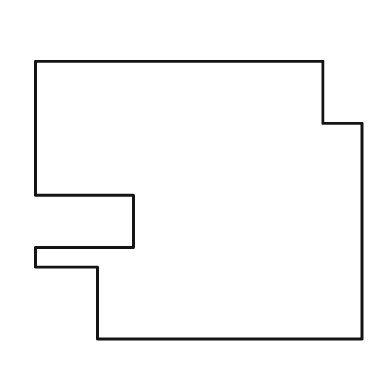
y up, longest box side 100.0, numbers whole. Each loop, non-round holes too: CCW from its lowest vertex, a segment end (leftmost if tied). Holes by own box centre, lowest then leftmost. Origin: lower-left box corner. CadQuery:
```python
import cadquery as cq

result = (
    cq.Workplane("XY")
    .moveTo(19.0, 0.0)
    .lineTo(100.0, 0.0)
    .lineTo(100.0, 66.0)
    .lineTo(88.0, 66.0)
    .lineTo(88.0, 85.0)
    .lineTo(0.0, 85.0)
    .lineTo(0.0, 44.0)
    .lineTo(30.0, 44.0)
    .lineTo(30.0, 28.0)
    .lineTo(0.0, 28.0)
    .lineTo(0.0, 22.0)
    .lineTo(19.0, 22.0)
    .close()
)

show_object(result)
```